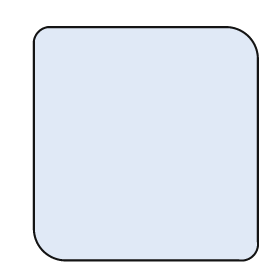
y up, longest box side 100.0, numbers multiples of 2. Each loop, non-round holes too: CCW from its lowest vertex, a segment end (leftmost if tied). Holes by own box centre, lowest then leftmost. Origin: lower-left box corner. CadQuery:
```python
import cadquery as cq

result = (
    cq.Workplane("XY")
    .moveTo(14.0, 0.0)
    .lineTo(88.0, 0.0)
    .threePointArc((94.0, 2.0), (96.0, 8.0))
    .lineTo(96.0, 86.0)
    .threePointArc((92.0, 96.0), (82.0, 100.0))
    .lineTo(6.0, 100.0)
    .threePointArc((2.0, 98.0), (0.0, 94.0))
    .lineTo(0.0, 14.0)
    .threePointArc((4.0, 4.0), (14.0, 0.0))
    .close()
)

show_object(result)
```